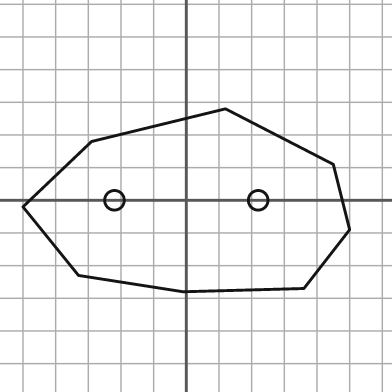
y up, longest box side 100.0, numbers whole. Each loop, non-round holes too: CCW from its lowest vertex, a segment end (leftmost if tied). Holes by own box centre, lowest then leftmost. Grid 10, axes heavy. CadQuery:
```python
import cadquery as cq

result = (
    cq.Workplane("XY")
    .moveTo(-1.0, -28.0)
    .lineTo(36.0, -27.0)
    .lineTo(50.0, -9.0)
    .lineTo(45.0, 11.0)
    .lineTo(12.0, 28.0)
    .lineTo(-29.0, 18.0)
    .lineTo(-50.0, -2.0)
    .lineTo(-33.0, -23.0)
    .close()
    .moveTo(-22.0, 0.0)
    .circle(3.0)
    .moveTo(22.0, 0.0)
    .circle(3.0)
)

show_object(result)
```